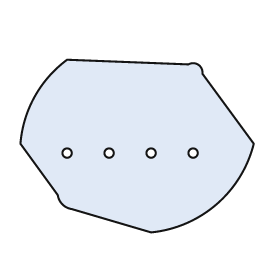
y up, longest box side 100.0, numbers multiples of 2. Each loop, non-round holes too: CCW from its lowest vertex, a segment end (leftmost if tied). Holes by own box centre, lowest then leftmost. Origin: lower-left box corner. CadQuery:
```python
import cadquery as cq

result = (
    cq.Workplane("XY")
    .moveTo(56.0, 0.0)
    .threePointArc((84.0, 12.0), (100.0, 38.0))
    .lineTo(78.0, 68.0)
    .threePointArc((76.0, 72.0), (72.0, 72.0))
    .lineTo(20.0, 74.0)
    .threePointArc((6.0, 58.0), (0.0, 38.0))
    .lineTo(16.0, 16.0)
    .threePointArc((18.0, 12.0), (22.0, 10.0))
    .close()
    .moveTo(20.0, 34.0)
    .circle(2.0)
    .moveTo(38.0, 34.0)
    .circle(2.0)
    .moveTo(56.0, 34.0)
    .circle(2.0)
    .moveTo(74.0, 34.0)
    .circle(2.0)
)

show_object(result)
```